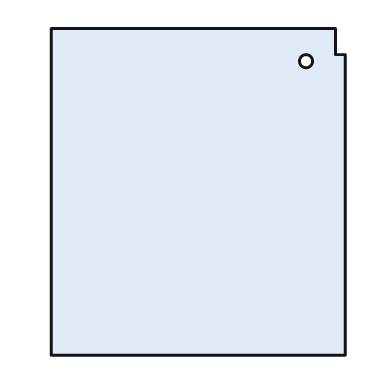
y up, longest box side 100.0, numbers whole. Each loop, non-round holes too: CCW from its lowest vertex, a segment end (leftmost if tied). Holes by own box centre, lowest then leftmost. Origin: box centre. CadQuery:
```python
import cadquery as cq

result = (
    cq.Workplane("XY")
    .moveTo(-45.0, -50.0)
    .lineTo(45.0, -50.0)
    .lineTo(45.0, 42.0)
    .lineTo(42.0, 42.0)
    .lineTo(42.0, 50.0)
    .lineTo(-45.0, 50.0)
    .close()
    .moveTo(33.0, 40.0)
    .circle(2.0)
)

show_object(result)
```